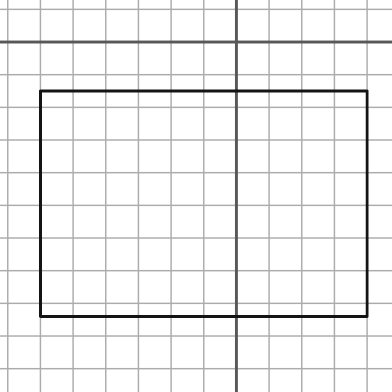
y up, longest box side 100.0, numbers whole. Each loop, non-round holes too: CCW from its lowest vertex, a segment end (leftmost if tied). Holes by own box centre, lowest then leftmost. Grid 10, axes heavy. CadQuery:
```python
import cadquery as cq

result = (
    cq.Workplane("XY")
    .moveTo(-60.0, -84.0)
    .lineTo(40.0, -84.0)
    .lineTo(40.0, -15.0)
    .lineTo(-60.0, -15.0)
    .close()
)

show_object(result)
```